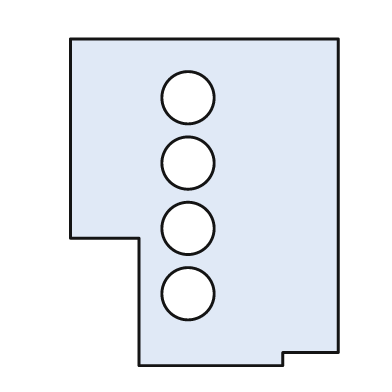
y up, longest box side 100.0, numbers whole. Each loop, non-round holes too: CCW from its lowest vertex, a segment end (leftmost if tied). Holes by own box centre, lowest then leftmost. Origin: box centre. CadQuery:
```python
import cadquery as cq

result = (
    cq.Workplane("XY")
    .moveTo(-20.0, -50.0)
    .lineTo(24.0, -50.0)
    .lineTo(24.0, -46.0)
    .lineTo(41.0, -46.0)
    .lineTo(41.0, 50.0)
    .lineTo(-41.0, 50.0)
    .lineTo(-41.0, -11.0)
    .lineTo(-20.0, -11.0)
    .close()
    .moveTo(-5.0, -28.0)
    .circle(8.0)
    .moveTo(-5.0, -8.0)
    .circle(8.0)
    .moveTo(-5.0, 12.0)
    .circle(8.0)
    .moveTo(-5.0, 32.0)
    .circle(8.0)
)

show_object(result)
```